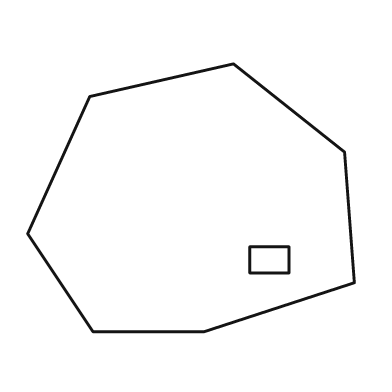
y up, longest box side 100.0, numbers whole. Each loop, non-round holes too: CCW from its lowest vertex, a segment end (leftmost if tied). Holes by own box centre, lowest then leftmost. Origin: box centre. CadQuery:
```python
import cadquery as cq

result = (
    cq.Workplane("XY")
    .moveTo(-30.0, -41.0)
    .lineTo(4.0, -41.0)
    .lineTo(50.0, -26.0)
    .lineTo(47.0, 14.0)
    .lineTo(13.0, 41.0)
    .lineTo(-31.0, 31.0)
    .lineTo(-50.0, -11.0)
    .close()
    .moveTo(18.0, -23.0)
    .lineTo(30.0, -23.0)
    .lineTo(30.0, -15.0)
    .lineTo(18.0, -15.0)
    .close()
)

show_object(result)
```